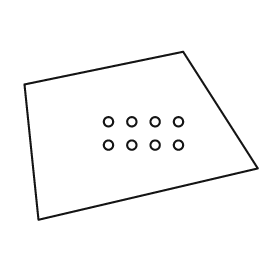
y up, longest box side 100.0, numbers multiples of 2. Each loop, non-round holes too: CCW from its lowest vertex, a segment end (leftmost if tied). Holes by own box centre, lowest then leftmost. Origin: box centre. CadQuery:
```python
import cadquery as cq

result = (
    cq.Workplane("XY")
    .moveTo(-44.0, -36.0)
    .lineTo(50.0, -14.0)
    .lineTo(18.0, 36.0)
    .lineTo(-50.0, 22.0)
    .close()
    .moveTo(-14.0, -4.0)
    .circle(2.0)
    .moveTo(-4.0, -4.0)
    .circle(2.0)
    .moveTo(6.0, -4.0)
    .circle(2.0)
    .moveTo(16.0, -4.0)
    .circle(2.0)
    .moveTo(-14.0, 6.0)
    .circle(2.0)
    .moveTo(-4.0, 6.0)
    .circle(2.0)
    .moveTo(6.0, 6.0)
    .circle(2.0)
    .moveTo(16.0, 6.0)
    .circle(2.0)
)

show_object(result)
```